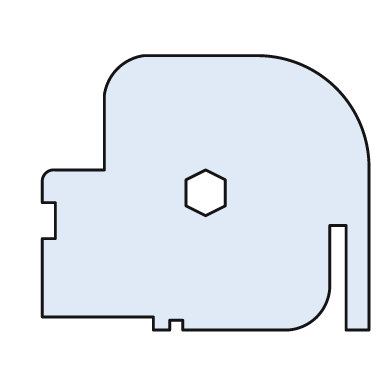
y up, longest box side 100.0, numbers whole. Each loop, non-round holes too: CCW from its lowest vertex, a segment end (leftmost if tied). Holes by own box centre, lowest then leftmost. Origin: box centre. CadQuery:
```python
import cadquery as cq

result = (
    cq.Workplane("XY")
    .moveTo(-16.0, -42.0)
    .lineTo(-11.0, -42.0)
    .lineTo(-11.0, -39.0)
    .lineTo(-7.0, -39.0)
    .lineTo(-7.0, -42.0)
    .lineTo(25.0, -42.0)
    .threePointArc((34.0, -38.0), (38.0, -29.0))
    .lineTo(38.0, -10.0)
    .lineTo(43.0, -10.0)
    .lineTo(43.0, -42.0)
    .lineTo(50.0, -42.0)
    .lineTo(50.0, 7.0)
    .threePointArc((40.0, 32.0), (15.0, 42.0))
    .lineTo(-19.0, 42.0)
    .threePointArc((-27.0, 38.0), (-31.0, 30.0))
    .lineTo(-31.0, 7.0)
    .lineTo(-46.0, 7.0)
    .threePointArc((-49.0, 6.0), (-50.0, 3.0))
    .lineTo(-50.0, -3.0)
    .lineTo(-46.0, -3.0)
    .lineTo(-46.0, -14.0)
    .lineTo(-50.0, -14.0)
    .lineTo(-50.0, -38.0)
    .lineTo(-16.0, -38.0)
    .close()
    .moveTo(0.0, -7.0)
    .lineTo(6.0, -4.0)
    .lineTo(6.0, 4.0)
    .lineTo(0.0, 7.0)
    .lineTo(-6.0, 4.0)
    .lineTo(-6.0, -4.0)
    .close()
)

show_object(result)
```